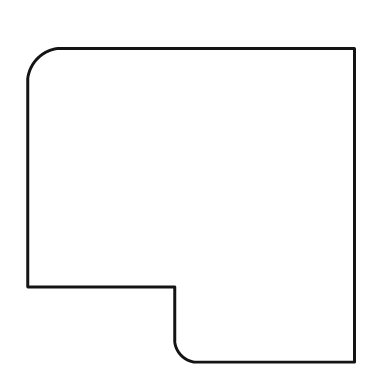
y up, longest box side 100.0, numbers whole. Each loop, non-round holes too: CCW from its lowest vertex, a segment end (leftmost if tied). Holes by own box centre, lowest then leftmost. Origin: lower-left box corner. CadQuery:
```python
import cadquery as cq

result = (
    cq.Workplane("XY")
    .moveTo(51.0, 0.0)
    .lineTo(100.0, 0.0)
    .lineTo(100.0, 96.0)
    .lineTo(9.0, 96.0)
    .threePointArc((3.0, 93.0), (0.0, 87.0))
    .lineTo(0.0, 23.0)
    .lineTo(45.0, 23.0)
    .lineTo(45.0, 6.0)
    .threePointArc((47.0, 2.0), (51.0, 0.0))
    .close()
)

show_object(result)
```